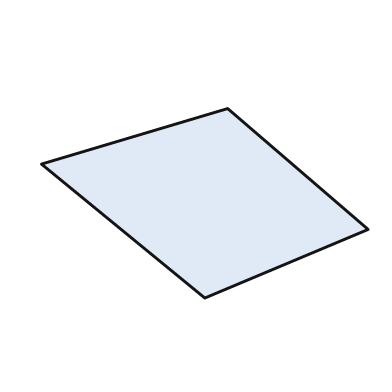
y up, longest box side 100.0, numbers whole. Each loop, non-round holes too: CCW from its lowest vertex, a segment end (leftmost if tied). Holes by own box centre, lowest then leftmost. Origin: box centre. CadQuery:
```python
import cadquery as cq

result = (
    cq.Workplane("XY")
    .moveTo(0.0, -29.0)
    .lineTo(50.0, -8.0)
    .lineTo(7.0, 29.0)
    .lineTo(-50.0, 12.0)
    .close()
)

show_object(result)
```